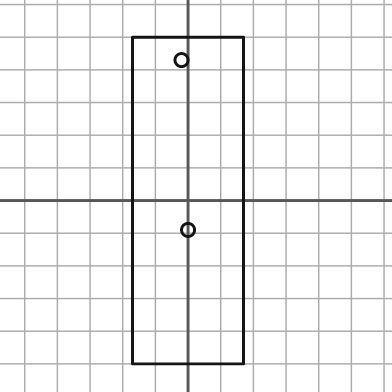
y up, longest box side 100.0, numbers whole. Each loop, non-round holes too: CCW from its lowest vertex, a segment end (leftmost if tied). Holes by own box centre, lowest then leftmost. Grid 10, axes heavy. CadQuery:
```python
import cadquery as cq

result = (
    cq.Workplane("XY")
    .moveTo(-17.0, -50.0)
    .lineTo(17.0, -50.0)
    .lineTo(17.0, 50.0)
    .lineTo(-17.0, 50.0)
    .close()
    .moveTo(0.0, -9.0)
    .circle(2.0)
    .moveTo(-2.0, 43.0)
    .circle(2.0)
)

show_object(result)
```